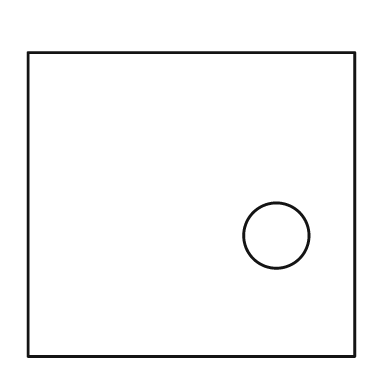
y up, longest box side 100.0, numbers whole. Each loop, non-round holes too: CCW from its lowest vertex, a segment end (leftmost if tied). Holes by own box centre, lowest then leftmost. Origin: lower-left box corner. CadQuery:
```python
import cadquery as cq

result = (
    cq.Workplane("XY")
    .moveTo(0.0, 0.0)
    .lineTo(100.0, 0.0)
    .lineTo(100.0, 93.0)
    .lineTo(0.0, 93.0)
    .close()
    .moveTo(76.0, 37.0)
    .circle(10.0)
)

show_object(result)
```